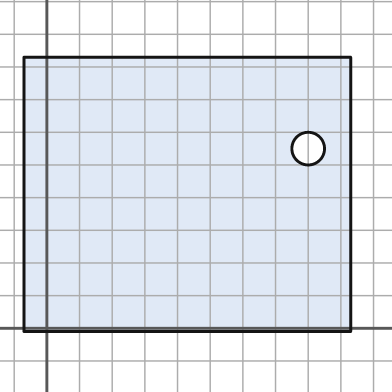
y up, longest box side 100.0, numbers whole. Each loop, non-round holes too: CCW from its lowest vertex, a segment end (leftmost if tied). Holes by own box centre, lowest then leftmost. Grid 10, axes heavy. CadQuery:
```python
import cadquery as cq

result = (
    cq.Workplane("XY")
    .moveTo(-7.0, -1.0)
    .lineTo(93.0, -1.0)
    .lineTo(93.0, 83.0)
    .lineTo(-7.0, 83.0)
    .close()
    .moveTo(80.0, 55.0)
    .circle(5.0)
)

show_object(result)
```